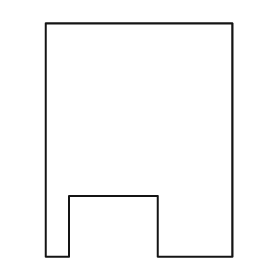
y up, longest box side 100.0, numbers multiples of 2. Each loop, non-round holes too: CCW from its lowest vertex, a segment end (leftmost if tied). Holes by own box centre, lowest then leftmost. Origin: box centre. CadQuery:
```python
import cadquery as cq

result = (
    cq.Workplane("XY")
    .moveTo(-40.0, -50.0)
    .lineTo(-30.0, -50.0)
    .lineTo(-30.0, -24.0)
    .lineTo(8.0, -24.0)
    .lineTo(8.0, -50.0)
    .lineTo(40.0, -50.0)
    .lineTo(40.0, 50.0)
    .lineTo(-40.0, 50.0)
    .close()
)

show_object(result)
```